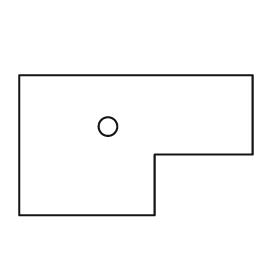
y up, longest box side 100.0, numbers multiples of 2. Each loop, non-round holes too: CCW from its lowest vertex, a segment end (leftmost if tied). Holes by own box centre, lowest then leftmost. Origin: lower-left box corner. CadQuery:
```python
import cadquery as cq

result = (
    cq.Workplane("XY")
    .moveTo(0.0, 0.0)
    .lineTo(58.0, 0.0)
    .lineTo(58.0, 26.0)
    .lineTo(100.0, 26.0)
    .lineTo(100.0, 60.0)
    .lineTo(0.0, 60.0)
    .close()
    .moveTo(38.0, 38.0)
    .circle(4.0)
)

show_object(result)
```